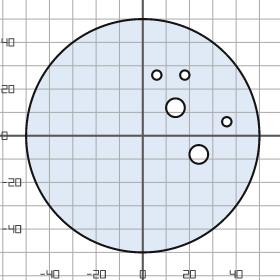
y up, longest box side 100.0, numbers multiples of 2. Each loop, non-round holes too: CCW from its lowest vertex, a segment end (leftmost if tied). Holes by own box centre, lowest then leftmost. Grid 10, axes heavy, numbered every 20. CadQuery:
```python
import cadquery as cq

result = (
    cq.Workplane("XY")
    .moveTo(0.0, 0.0)
    .circle(50.0)
    .moveTo(24.0, -8.0)
    .circle(4.0)
    .moveTo(36.0, 6.0)
    .circle(2.0)
    .moveTo(14.0, 12.0)
    .circle(4.0)
    .moveTo(6.0, 26.0)
    .circle(2.0)
    .moveTo(18.0, 26.0)
    .circle(2.0)
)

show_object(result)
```